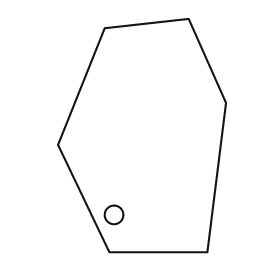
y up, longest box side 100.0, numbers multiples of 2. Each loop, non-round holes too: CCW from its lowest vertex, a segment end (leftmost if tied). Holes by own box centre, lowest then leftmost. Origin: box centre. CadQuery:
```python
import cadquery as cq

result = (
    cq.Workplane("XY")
    .moveTo(-14.0, -50.0)
    .lineTo(28.0, -50.0)
    .lineTo(36.0, 14.0)
    .lineTo(20.0, 50.0)
    .lineTo(-16.0, 46.0)
    .lineTo(-36.0, -4.0)
    .close()
    .moveTo(-12.0, -34.0)
    .circle(4.0)
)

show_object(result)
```